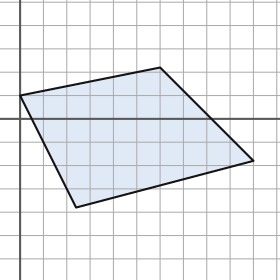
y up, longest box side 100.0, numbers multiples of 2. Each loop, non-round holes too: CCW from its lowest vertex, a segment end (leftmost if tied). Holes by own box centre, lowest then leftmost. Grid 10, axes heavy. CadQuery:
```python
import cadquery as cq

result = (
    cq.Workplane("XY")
    .moveTo(24.0, -38.0)
    .lineTo(100.0, -18.0)
    .lineTo(60.0, 22.0)
    .lineTo(0.0, 10.0)
    .close()
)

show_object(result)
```